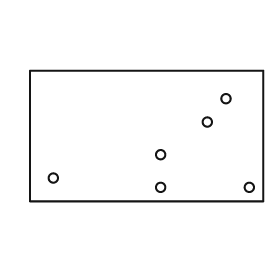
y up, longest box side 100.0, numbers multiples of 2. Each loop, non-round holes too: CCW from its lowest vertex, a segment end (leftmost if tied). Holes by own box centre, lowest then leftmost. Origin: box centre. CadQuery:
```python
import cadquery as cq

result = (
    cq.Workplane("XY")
    .moveTo(-50.0, -28.0)
    .lineTo(50.0, -28.0)
    .lineTo(50.0, 28.0)
    .lineTo(-50.0, 28.0)
    .close()
    .moveTo(6.0, -22.0)
    .circle(2.0)
    .moveTo(44.0, -22.0)
    .circle(2.0)
    .moveTo(-40.0, -18.0)
    .circle(2.0)
    .moveTo(6.0, -8.0)
    .circle(2.0)
    .moveTo(26.0, 6.0)
    .circle(2.0)
    .moveTo(34.0, 16.0)
    .circle(2.0)
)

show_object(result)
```